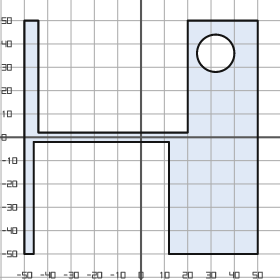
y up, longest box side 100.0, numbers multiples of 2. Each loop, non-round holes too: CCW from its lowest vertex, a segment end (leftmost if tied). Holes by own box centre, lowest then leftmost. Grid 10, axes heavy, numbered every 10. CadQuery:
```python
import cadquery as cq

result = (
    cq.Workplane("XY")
    .moveTo(-50.0, -50.0)
    .lineTo(-46.0, -50.0)
    .lineTo(-46.0, -2.0)
    .lineTo(12.0, -2.0)
    .lineTo(12.0, -50.0)
    .lineTo(50.0, -50.0)
    .lineTo(50.0, 50.0)
    .lineTo(20.0, 50.0)
    .lineTo(20.0, 2.0)
    .lineTo(-44.0, 2.0)
    .lineTo(-44.0, 50.0)
    .lineTo(-50.0, 50.0)
    .close()
    .moveTo(32.0, 36.0)
    .circle(8.0)
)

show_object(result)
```